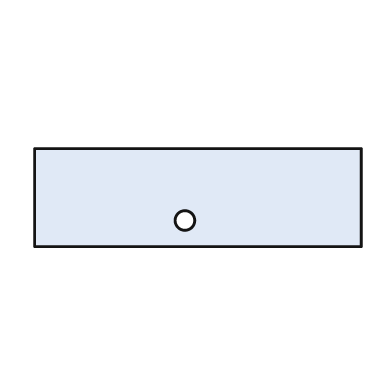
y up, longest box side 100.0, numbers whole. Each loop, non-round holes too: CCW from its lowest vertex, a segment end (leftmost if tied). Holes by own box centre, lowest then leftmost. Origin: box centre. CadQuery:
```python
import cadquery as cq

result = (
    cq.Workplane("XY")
    .moveTo(-50.0, -15.0)
    .lineTo(50.0, -15.0)
    .lineTo(50.0, 15.0)
    .lineTo(-50.0, 15.0)
    .close()
    .moveTo(-4.0, -7.0)
    .circle(3.0)
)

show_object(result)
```